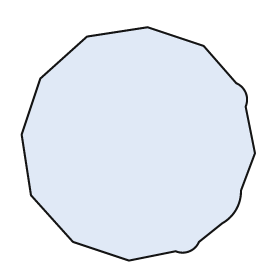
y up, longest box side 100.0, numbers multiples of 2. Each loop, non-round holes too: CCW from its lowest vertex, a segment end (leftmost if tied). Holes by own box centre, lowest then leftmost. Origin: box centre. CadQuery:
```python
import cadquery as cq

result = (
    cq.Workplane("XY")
    .moveTo(-4.0, -50.0)
    .lineTo(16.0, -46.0)
    .threePointArc((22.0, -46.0), (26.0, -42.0))
    .lineTo(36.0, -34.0)
    .threePointArc((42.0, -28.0), (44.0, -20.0))
    .lineTo(50.0, -4.0)
    .lineTo(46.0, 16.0)
    .threePointArc((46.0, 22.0), (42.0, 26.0))
    .lineTo(28.0, 42.0)
    .lineTo(4.0, 50.0)
    .lineTo(-22.0, 46.0)
    .lineTo(-42.0, 28.0)
    .lineTo(-50.0, 4.0)
    .lineTo(-46.0, -22.0)
    .lineTo(-28.0, -42.0)
    .close()
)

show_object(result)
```